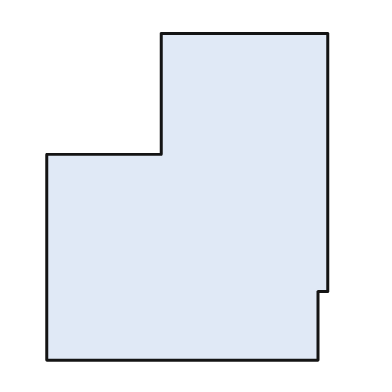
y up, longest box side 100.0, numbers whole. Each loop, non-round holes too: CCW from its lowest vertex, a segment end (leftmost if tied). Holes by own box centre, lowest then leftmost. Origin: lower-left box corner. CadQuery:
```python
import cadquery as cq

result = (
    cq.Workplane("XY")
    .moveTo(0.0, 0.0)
    .lineTo(83.0, 0.0)
    .lineTo(83.0, 21.0)
    .lineTo(86.0, 21.0)
    .lineTo(86.0, 100.0)
    .lineTo(35.0, 100.0)
    .lineTo(35.0, 63.0)
    .lineTo(0.0, 63.0)
    .close()
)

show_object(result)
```